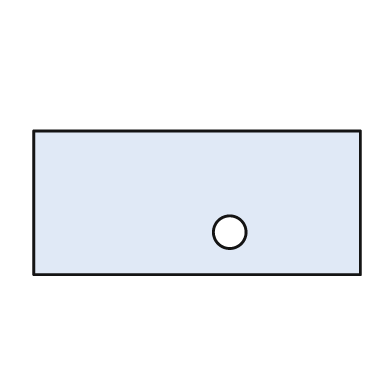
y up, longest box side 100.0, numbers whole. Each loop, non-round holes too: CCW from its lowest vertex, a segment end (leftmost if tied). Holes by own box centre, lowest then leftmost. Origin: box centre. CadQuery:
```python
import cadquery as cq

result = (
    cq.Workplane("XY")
    .moveTo(-50.0, -22.0)
    .lineTo(50.0, -22.0)
    .lineTo(50.0, 22.0)
    .lineTo(-50.0, 22.0)
    .close()
    .moveTo(10.0, -9.0)
    .circle(5.0)
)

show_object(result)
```